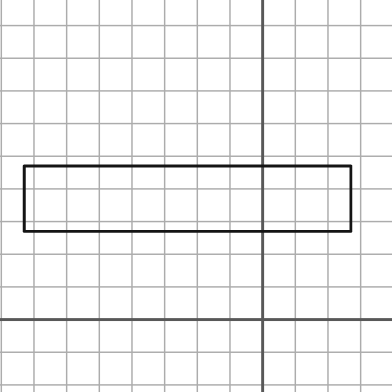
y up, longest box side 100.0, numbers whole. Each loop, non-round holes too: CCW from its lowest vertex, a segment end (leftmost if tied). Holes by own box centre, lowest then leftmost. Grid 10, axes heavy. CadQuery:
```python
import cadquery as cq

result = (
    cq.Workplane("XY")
    .moveTo(-73.0, 27.0)
    .lineTo(27.0, 27.0)
    .lineTo(27.0, 47.0)
    .lineTo(-73.0, 47.0)
    .close()
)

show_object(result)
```